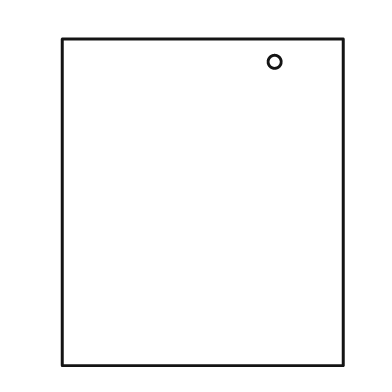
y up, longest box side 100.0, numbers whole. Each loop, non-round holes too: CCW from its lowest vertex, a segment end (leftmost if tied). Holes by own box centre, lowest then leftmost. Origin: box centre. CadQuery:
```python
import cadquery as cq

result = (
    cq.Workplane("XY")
    .moveTo(-43.0, -50.0)
    .lineTo(43.0, -50.0)
    .lineTo(43.0, 50.0)
    .lineTo(-43.0, 50.0)
    .close()
    .moveTo(22.0, 43.0)
    .circle(2.0)
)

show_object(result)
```